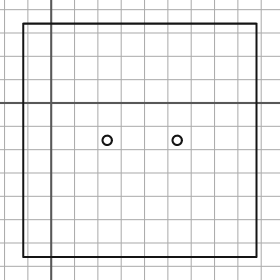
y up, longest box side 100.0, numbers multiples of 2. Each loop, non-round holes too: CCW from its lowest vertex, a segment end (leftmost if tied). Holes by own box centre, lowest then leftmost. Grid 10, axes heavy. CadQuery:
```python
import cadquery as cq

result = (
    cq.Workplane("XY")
    .moveTo(-12.0, -66.0)
    .lineTo(88.0, -66.0)
    .lineTo(88.0, 34.0)
    .lineTo(-12.0, 34.0)
    .close()
    .moveTo(24.0, -16.0)
    .circle(2.0)
    .moveTo(54.0, -16.0)
    .circle(2.0)
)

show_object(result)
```